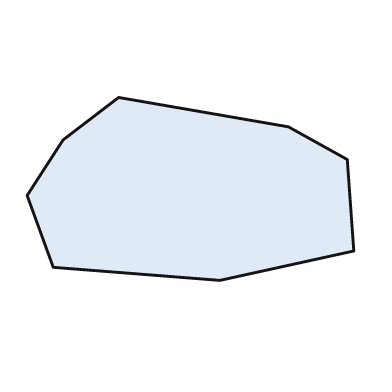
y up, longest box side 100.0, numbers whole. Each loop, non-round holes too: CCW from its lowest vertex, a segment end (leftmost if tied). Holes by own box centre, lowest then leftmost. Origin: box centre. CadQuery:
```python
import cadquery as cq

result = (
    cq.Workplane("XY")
    .moveTo(9.0, -28.0)
    .lineTo(50.0, -19.0)
    .lineTo(48.0, 9.0)
    .lineTo(30.0, 19.0)
    .lineTo(-22.0, 28.0)
    .lineTo(-39.0, 15.0)
    .lineTo(-50.0, -2.0)
    .lineTo(-42.0, -24.0)
    .close()
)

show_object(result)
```